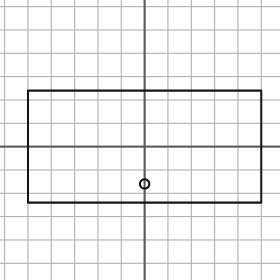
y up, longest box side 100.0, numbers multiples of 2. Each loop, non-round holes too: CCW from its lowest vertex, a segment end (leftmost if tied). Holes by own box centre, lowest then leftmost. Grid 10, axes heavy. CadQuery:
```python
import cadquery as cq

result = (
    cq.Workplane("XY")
    .moveTo(-50.0, -24.0)
    .lineTo(50.0, -24.0)
    .lineTo(50.0, 24.0)
    .lineTo(-50.0, 24.0)
    .close()
    .moveTo(0.0, -16.0)
    .circle(2.0)
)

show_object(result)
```